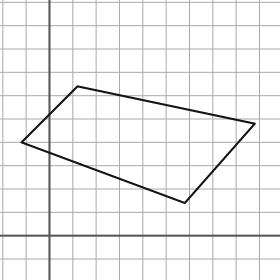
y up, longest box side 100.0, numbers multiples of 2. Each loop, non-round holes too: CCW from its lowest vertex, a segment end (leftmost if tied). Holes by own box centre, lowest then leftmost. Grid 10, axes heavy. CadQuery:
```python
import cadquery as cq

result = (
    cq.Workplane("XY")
    .moveTo(58.0, 14.0)
    .lineTo(88.0, 48.0)
    .lineTo(12.0, 64.0)
    .lineTo(-12.0, 40.0)
    .close()
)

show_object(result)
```